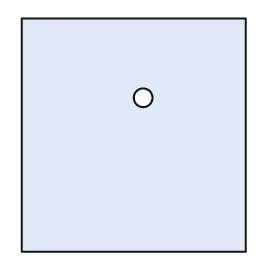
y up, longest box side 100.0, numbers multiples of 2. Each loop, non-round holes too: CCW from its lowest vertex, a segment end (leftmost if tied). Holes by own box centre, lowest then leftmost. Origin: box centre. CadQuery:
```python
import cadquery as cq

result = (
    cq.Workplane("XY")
    .moveTo(-48.0, -50.0)
    .lineTo(48.0, -50.0)
    .lineTo(48.0, 50.0)
    .lineTo(-48.0, 50.0)
    .close()
    .moveTo(4.0, 16.0)
    .circle(4.0)
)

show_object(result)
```